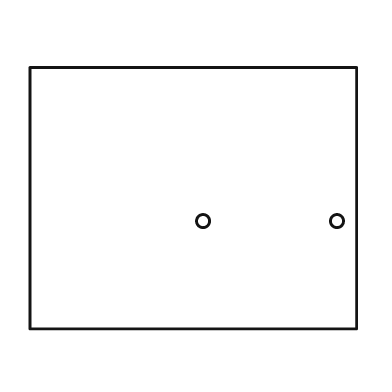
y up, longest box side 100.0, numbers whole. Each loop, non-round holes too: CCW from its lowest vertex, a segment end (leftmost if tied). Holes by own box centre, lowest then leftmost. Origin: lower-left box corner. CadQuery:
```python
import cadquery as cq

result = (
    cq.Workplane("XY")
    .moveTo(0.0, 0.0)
    .lineTo(100.0, 0.0)
    .lineTo(100.0, 80.0)
    .lineTo(0.0, 80.0)
    .close()
    .moveTo(53.0, 33.0)
    .circle(2.0)
    .moveTo(94.0, 33.0)
    .circle(2.0)
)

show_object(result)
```